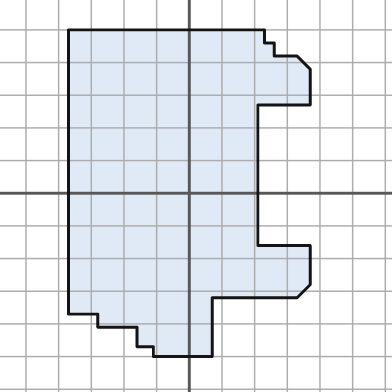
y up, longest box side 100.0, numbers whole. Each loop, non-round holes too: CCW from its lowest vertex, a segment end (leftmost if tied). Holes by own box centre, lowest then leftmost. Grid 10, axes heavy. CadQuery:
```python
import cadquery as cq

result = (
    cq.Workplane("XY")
    .moveTo(-11.0, -50.0)
    .lineTo(7.0, -50.0)
    .lineTo(7.0, -32.0)
    .lineTo(33.0, -32.0)
    .lineTo(37.0, -28.0)
    .lineTo(37.0, -16.0)
    .lineTo(21.0, -16.0)
    .lineTo(21.0, 27.0)
    .lineTo(37.0, 27.0)
    .lineTo(37.0, 38.0)
    .lineTo(33.0, 42.0)
    .lineTo(26.0, 42.0)
    .lineTo(26.0, 46.0)
    .lineTo(23.0, 46.0)
    .lineTo(23.0, 50.0)
    .lineTo(-37.0, 50.0)
    .lineTo(-37.0, -37.0)
    .lineTo(-28.0, -37.0)
    .lineTo(-28.0, -41.0)
    .lineTo(-16.0, -41.0)
    .lineTo(-16.0, -47.0)
    .lineTo(-11.0, -47.0)
    .close()
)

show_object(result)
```